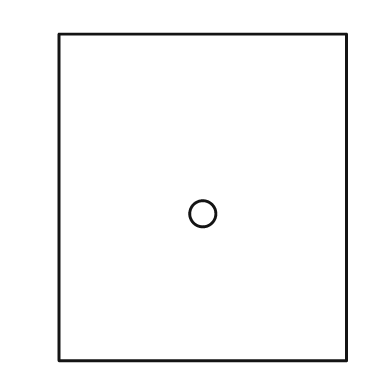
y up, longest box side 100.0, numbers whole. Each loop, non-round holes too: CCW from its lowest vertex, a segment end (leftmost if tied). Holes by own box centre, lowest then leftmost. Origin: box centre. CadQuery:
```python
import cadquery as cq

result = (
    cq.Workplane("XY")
    .moveTo(-44.0, -50.0)
    .lineTo(44.0, -50.0)
    .lineTo(44.0, 50.0)
    .lineTo(-44.0, 50.0)
    .close()
    .moveTo(0.0, -5.0)
    .circle(4.0)
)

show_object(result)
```